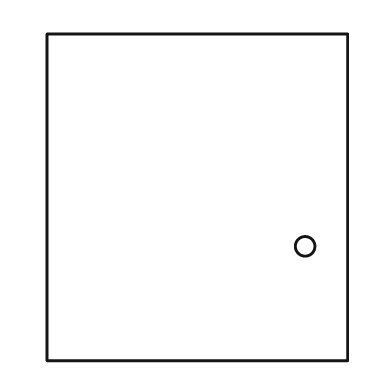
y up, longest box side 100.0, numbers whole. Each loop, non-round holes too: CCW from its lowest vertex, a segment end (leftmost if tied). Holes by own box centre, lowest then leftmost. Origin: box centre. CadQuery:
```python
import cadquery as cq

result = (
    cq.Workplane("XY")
    .moveTo(-46.0, -50.0)
    .lineTo(46.0, -50.0)
    .lineTo(46.0, 50.0)
    .lineTo(-46.0, 50.0)
    .close()
    .moveTo(33.0, -15.0)
    .circle(3.0)
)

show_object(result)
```